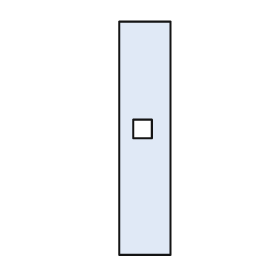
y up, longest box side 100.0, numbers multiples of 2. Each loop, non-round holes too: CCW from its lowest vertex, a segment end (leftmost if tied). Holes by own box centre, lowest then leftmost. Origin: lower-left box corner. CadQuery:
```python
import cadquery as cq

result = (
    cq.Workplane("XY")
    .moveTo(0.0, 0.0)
    .lineTo(22.0, 0.0)
    .lineTo(22.0, 100.0)
    .lineTo(0.0, 100.0)
    .close()
    .moveTo(6.0, 50.0)
    .lineTo(14.0, 50.0)
    .lineTo(14.0, 58.0)
    .lineTo(6.0, 58.0)
    .close()
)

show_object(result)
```